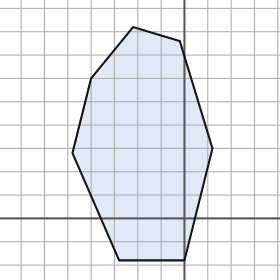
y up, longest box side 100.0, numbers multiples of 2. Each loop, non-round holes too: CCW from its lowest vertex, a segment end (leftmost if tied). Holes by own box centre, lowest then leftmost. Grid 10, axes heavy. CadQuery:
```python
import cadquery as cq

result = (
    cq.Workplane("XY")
    .moveTo(-28.0, -18.0)
    .lineTo(0.0, -18.0)
    .lineTo(12.0, 30.0)
    .lineTo(-2.0, 76.0)
    .lineTo(-22.0, 82.0)
    .lineTo(-40.0, 60.0)
    .lineTo(-48.0, 28.0)
    .close()
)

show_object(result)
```